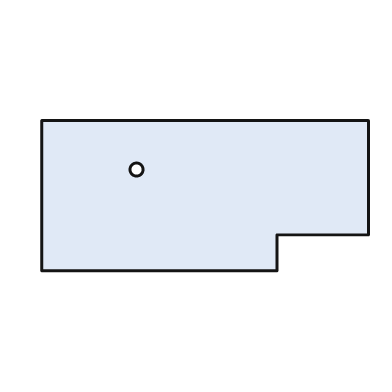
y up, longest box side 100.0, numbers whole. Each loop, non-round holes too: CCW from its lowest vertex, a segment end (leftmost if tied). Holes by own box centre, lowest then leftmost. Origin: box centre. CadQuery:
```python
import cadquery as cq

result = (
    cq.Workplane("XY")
    .moveTo(-50.0, -23.0)
    .lineTo(22.0, -23.0)
    .lineTo(22.0, -12.0)
    .lineTo(50.0, -12.0)
    .lineTo(50.0, 23.0)
    .lineTo(-50.0, 23.0)
    .close()
    .moveTo(-21.0, 8.0)
    .circle(2.0)
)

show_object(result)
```